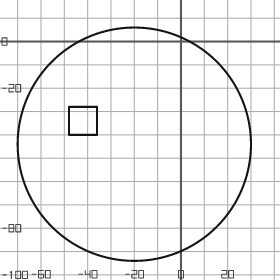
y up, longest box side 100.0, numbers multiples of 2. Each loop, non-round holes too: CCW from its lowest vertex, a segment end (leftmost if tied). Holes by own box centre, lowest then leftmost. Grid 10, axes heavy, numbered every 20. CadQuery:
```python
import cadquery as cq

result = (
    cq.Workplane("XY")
    .moveTo(-20.0, -44.0)
    .circle(50.0)
    .moveTo(-48.0, -40.0)
    .lineTo(-36.0, -40.0)
    .lineTo(-36.0, -28.0)
    .lineTo(-48.0, -28.0)
    .close()
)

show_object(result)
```